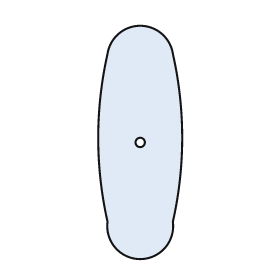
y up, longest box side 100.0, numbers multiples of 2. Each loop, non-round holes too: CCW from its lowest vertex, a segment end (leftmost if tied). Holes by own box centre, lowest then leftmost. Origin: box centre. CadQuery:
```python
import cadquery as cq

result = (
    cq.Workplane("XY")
    .moveTo(-14.0, -34.0)
    .threePointArc((0.0, -50.0), (14.0, -34.0))
    .threePointArc((18.0, 2.0), (14.0, 38.0))
    .threePointArc((0.0, 50.0), (-14.0, 38.0))
    .threePointArc((-18.0, 2.0), (-14.0, -34.0))
    .close()
    .moveTo(0.0, 0.0)
    .circle(2.0)
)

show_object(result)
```